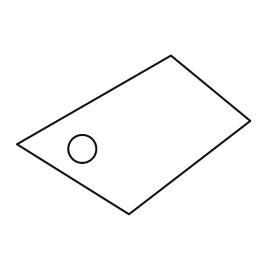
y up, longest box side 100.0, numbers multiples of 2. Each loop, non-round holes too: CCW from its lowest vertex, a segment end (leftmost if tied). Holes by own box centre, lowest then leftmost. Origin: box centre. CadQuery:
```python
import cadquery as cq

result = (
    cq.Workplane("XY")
    .moveTo(-2.0, -34.0)
    .lineTo(50.0, 6.0)
    .lineTo(16.0, 34.0)
    .lineTo(-50.0, -4.0)
    .close()
    .moveTo(-22.0, -6.0)
    .circle(6.0)
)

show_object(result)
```